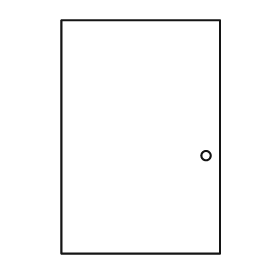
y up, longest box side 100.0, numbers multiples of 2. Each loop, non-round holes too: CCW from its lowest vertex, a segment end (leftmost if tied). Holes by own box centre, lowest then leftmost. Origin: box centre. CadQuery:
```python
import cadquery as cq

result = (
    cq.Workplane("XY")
    .moveTo(-34.0, -50.0)
    .lineTo(34.0, -50.0)
    .lineTo(34.0, 50.0)
    .lineTo(-34.0, 50.0)
    .close()
    .moveTo(28.0, -8.0)
    .circle(2.0)
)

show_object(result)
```